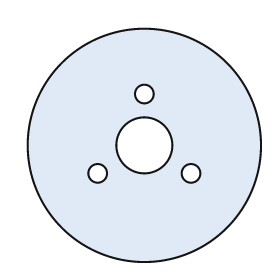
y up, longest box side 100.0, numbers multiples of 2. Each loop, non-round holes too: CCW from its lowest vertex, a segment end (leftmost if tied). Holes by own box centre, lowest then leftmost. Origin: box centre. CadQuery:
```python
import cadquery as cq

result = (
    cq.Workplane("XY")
    .moveTo(0.0, 0.0)
    .circle(50.0)
    .moveTo(-20.0, -12.0)
    .circle(4.0)
    .moveTo(20.0, -12.0)
    .circle(4.0)
    .moveTo(0.0, 0.0)
    .circle(12.0)
    .moveTo(0.0, 22.0)
    .circle(4.0)
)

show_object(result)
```